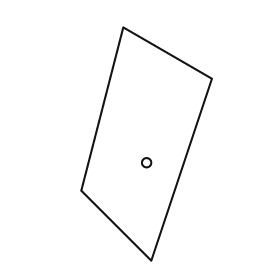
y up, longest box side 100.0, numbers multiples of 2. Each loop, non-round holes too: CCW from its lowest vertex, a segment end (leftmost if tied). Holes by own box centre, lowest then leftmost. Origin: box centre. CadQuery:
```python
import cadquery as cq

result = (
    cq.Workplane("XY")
    .moveTo(2.0, -50.0)
    .lineTo(28.0, 28.0)
    .lineTo(-10.0, 50.0)
    .lineTo(-28.0, -20.0)
    .close()
    .moveTo(0.0, -8.0)
    .circle(2.0)
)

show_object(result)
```